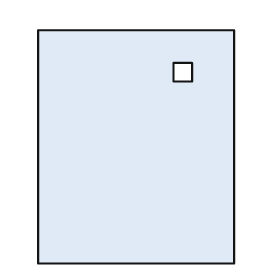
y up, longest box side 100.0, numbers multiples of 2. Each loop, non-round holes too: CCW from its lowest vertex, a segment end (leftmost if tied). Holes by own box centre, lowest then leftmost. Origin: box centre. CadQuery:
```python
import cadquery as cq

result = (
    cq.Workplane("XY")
    .moveTo(-42.0, -50.0)
    .lineTo(42.0, -50.0)
    .lineTo(42.0, 50.0)
    .lineTo(-42.0, 50.0)
    .close()
    .moveTo(16.0, 28.0)
    .lineTo(24.0, 28.0)
    .lineTo(24.0, 36.0)
    .lineTo(16.0, 36.0)
    .close()
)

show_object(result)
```